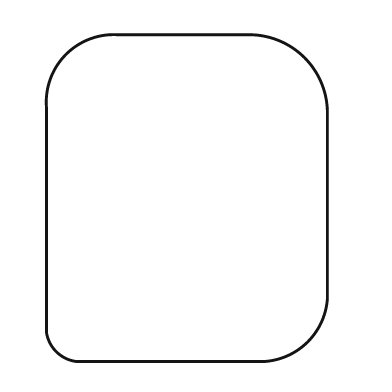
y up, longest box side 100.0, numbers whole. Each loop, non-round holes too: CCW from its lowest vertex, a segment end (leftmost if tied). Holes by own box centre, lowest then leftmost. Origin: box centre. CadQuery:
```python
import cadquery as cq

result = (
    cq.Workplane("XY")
    .moveTo(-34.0, -50.0)
    .lineTo(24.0, -50.0)
    .threePointArc((37.0, -44.0), (43.0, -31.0))
    .lineTo(43.0, 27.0)
    .threePointArc((36.0, 43.0), (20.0, 50.0))
    .lineTo(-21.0, 50.0)
    .threePointArc((-37.0, 44.0), (-43.0, 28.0))
    .lineTo(-43.0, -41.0)
    .threePointArc((-40.0, -47.0), (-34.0, -50.0))
    .close()
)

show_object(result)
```